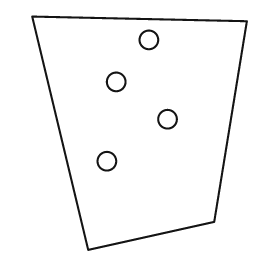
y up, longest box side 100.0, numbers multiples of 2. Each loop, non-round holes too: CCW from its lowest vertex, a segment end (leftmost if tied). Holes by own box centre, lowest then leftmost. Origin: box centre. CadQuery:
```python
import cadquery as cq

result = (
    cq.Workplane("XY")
    .moveTo(-22.0, -50.0)
    .lineTo(32.0, -38.0)
    .lineTo(46.0, 48.0)
    .lineTo(-46.0, 50.0)
    .close()
    .moveTo(-14.0, -12.0)
    .circle(4.0)
    .moveTo(12.0, 6.0)
    .circle(4.0)
    .moveTo(-10.0, 22.0)
    .circle(4.0)
    .moveTo(4.0, 40.0)
    .circle(4.0)
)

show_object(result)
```